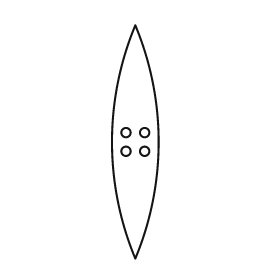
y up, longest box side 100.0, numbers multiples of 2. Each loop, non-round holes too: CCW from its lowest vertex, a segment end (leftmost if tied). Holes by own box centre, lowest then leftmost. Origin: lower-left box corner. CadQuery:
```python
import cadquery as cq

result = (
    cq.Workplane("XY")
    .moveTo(10.0, 0.0)
    .threePointArc((20.0, 50.0), (10.0, 100.0))
    .threePointArc((0.0, 50.0), (10.0, 0.0))
    .close()
    .moveTo(6.0, 46.0)
    .circle(2.0)
    .moveTo(14.0, 46.0)
    .circle(2.0)
    .moveTo(6.0, 54.0)
    .circle(2.0)
    .moveTo(14.0, 54.0)
    .circle(2.0)
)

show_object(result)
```